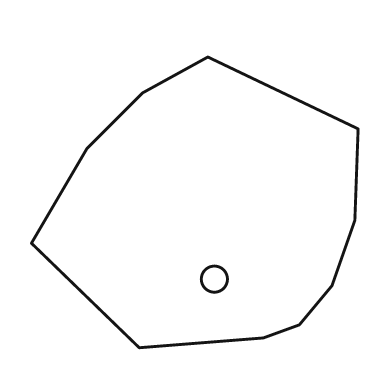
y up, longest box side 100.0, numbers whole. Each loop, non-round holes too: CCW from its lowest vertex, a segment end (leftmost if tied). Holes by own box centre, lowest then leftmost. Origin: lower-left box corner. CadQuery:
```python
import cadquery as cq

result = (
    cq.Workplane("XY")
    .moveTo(33.0, 0.0)
    .lineTo(71.0, 3.0)
    .lineTo(82.0, 7.0)
    .lineTo(92.0, 19.0)
    .lineTo(99.0, 39.0)
    .lineTo(100.0, 67.0)
    .lineTo(54.0, 89.0)
    .lineTo(34.0, 78.0)
    .lineTo(17.0, 61.0)
    .lineTo(0.0, 32.0)
    .close()
    .moveTo(56.0, 21.0)
    .circle(4.0)
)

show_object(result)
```